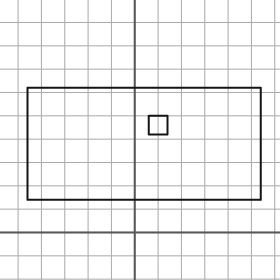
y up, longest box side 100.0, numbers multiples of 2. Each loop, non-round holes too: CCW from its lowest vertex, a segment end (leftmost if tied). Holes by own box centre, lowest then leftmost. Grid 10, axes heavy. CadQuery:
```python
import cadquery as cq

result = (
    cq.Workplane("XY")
    .moveTo(-46.0, 14.0)
    .lineTo(54.0, 14.0)
    .lineTo(54.0, 62.0)
    .lineTo(-46.0, 62.0)
    .close()
    .moveTo(6.0, 42.0)
    .lineTo(14.0, 42.0)
    .lineTo(14.0, 50.0)
    .lineTo(6.0, 50.0)
    .close()
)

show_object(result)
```